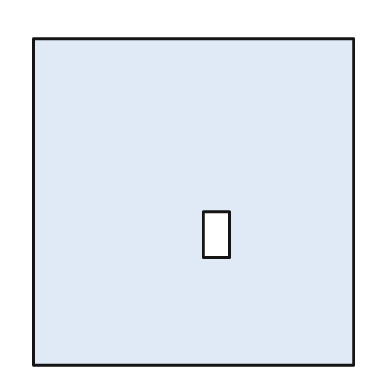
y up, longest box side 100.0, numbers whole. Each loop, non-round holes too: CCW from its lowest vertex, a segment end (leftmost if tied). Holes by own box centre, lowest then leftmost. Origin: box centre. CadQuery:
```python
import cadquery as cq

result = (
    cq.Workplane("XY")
    .moveTo(-49.0, -50.0)
    .lineTo(49.0, -50.0)
    .lineTo(49.0, 50.0)
    .lineTo(-49.0, 50.0)
    .close()
    .moveTo(3.0, -17.0)
    .lineTo(11.0, -17.0)
    .lineTo(11.0, -3.0)
    .lineTo(3.0, -3.0)
    .close()
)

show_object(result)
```